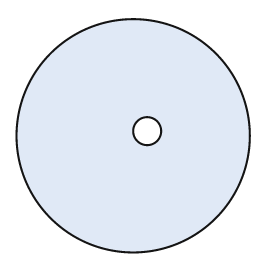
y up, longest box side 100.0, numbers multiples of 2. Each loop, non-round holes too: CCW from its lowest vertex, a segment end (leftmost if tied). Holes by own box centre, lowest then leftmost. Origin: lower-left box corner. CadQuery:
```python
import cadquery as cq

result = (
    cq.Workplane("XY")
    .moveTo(50.0, 50.0)
    .circle(50.0)
    .moveTo(56.0, 52.0)
    .circle(6.0)
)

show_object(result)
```